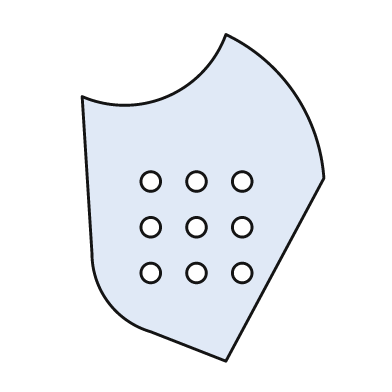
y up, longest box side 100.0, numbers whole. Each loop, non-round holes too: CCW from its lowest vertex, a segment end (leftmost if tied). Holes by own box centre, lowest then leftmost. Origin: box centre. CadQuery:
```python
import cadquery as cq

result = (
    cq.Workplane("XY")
    .moveTo(7.0, -50.0)
    .lineTo(37.0, 6.0)
    .threePointArc((28.0, 32.0), (7.0, 50.0))
    .threePointArc((-11.0, 31.0), (-37.0, 31.0))
    .lineTo(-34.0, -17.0)
    .threePointArc((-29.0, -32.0), (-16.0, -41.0))
    .close()
    .moveTo(-16.0, -23.0)
    .circle(3.0)
    .moveTo(-2.0, -23.0)
    .circle(3.0)
    .moveTo(12.0, -23.0)
    .circle(3.0)
    .moveTo(-16.0, -9.0)
    .circle(3.0)
    .moveTo(-2.0, -9.0)
    .circle(3.0)
    .moveTo(12.0, -9.0)
    .circle(3.0)
    .moveTo(-16.0, 5.0)
    .circle(3.0)
    .moveTo(-2.0, 5.0)
    .circle(3.0)
    .moveTo(12.0, 5.0)
    .circle(3.0)
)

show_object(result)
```